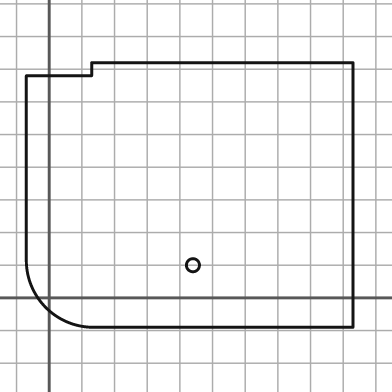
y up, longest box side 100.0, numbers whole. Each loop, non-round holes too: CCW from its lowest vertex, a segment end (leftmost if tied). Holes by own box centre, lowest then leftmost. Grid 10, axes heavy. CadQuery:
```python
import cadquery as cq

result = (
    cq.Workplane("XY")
    .moveTo(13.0, -9.0)
    .lineTo(93.0, -9.0)
    .lineTo(93.0, 72.0)
    .lineTo(13.0, 72.0)
    .lineTo(13.0, 68.0)
    .lineTo(-7.0, 68.0)
    .lineTo(-7.0, 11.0)
    .threePointArc((-1.0, -3.0), (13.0, -9.0))
    .close()
    .moveTo(44.0, 10.0)
    .circle(2.0)
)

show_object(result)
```